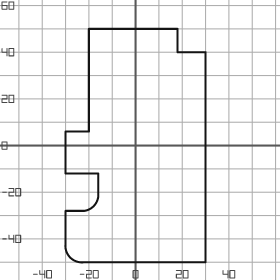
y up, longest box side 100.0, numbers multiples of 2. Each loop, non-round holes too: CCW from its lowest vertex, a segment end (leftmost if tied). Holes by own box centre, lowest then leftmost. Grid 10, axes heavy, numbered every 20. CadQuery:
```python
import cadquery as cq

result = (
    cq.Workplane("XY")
    .moveTo(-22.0, -50.0)
    .lineTo(30.0, -50.0)
    .lineTo(30.0, 40.0)
    .lineTo(18.0, 40.0)
    .lineTo(18.0, 50.0)
    .lineTo(-20.0, 50.0)
    .lineTo(-20.0, 6.0)
    .lineTo(-30.0, 6.0)
    .lineTo(-30.0, -12.0)
    .lineTo(-16.0, -12.0)
    .lineTo(-16.0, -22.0)
    .threePointArc((-18.0, -26.0), (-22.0, -28.0))
    .lineTo(-30.0, -28.0)
    .lineTo(-30.0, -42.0)
    .threePointArc((-28.0, -48.0), (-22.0, -50.0))
    .close()
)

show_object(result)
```